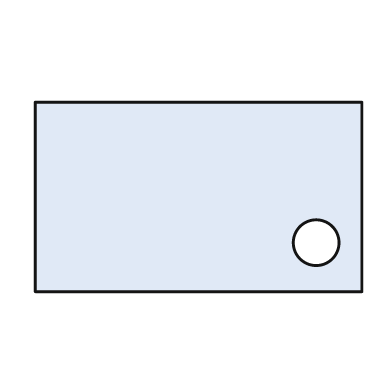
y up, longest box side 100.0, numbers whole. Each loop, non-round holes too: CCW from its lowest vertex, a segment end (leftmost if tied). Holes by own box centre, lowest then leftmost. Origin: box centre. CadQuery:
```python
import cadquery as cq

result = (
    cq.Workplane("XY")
    .moveTo(-50.0, -29.0)
    .lineTo(50.0, -29.0)
    .lineTo(50.0, 29.0)
    .lineTo(-50.0, 29.0)
    .close()
    .moveTo(36.0, -14.0)
    .circle(7.0)
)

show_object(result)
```